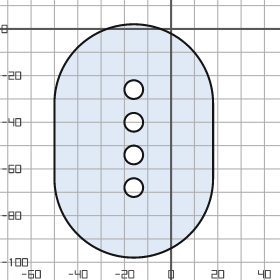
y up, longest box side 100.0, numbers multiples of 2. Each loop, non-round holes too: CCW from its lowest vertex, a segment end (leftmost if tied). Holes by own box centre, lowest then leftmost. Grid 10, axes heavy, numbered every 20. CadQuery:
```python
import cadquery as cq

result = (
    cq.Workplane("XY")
    .moveTo(-50.0, -64.0)
    .threePointArc((-16.0, -98.0), (18.0, -64.0))
    .lineTo(18.0, -32.0)
    .threePointArc((-16.0, 2.0), (-50.0, -32.0))
    .close()
    .moveTo(-16.0, -68.0)
    .circle(4.0)
    .moveTo(-16.0, -54.0)
    .circle(4.0)
    .moveTo(-16.0, -40.0)
    .circle(4.0)
    .moveTo(-16.0, -26.0)
    .circle(4.0)
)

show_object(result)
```